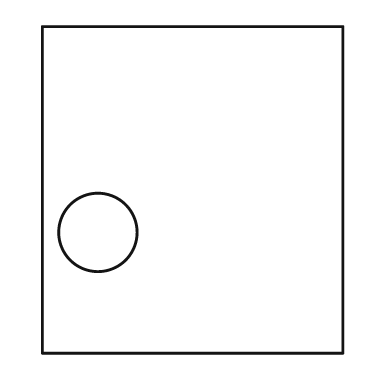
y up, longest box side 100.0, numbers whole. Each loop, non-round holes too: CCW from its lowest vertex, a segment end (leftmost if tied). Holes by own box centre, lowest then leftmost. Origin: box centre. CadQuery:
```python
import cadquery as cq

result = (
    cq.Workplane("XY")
    .moveTo(-46.0, -50.0)
    .lineTo(46.0, -50.0)
    .lineTo(46.0, 50.0)
    .lineTo(-46.0, 50.0)
    .close()
    .moveTo(-29.0, -13.0)
    .circle(12.0)
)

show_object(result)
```